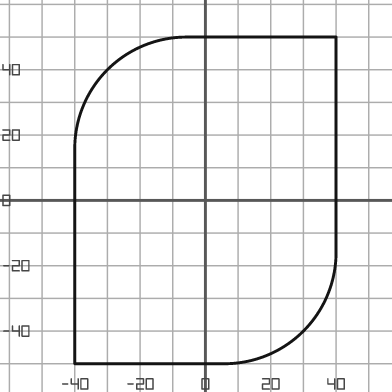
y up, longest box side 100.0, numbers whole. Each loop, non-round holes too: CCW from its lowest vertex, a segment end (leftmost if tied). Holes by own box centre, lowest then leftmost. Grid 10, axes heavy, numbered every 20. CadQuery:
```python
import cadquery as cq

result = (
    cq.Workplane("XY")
    .moveTo(-40.0, -50.0)
    .lineTo(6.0, -50.0)
    .threePointArc((30.0, -40.0), (40.0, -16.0))
    .lineTo(40.0, 50.0)
    .lineTo(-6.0, 50.0)
    .threePointArc((-30.0, 40.0), (-40.0, 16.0))
    .close()
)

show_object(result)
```